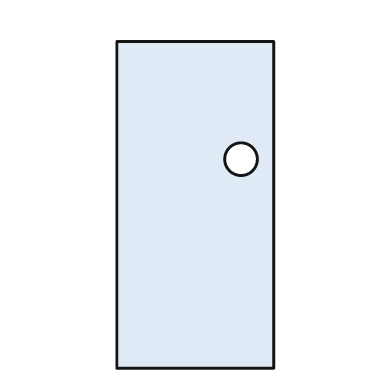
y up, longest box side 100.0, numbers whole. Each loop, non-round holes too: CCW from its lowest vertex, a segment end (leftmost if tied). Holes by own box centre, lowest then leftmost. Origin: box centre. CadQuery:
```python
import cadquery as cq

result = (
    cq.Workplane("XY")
    .moveTo(-24.0, -50.0)
    .lineTo(24.0, -50.0)
    .lineTo(24.0, 50.0)
    .lineTo(-24.0, 50.0)
    .close()
    .moveTo(14.0, 14.0)
    .circle(5.0)
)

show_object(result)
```